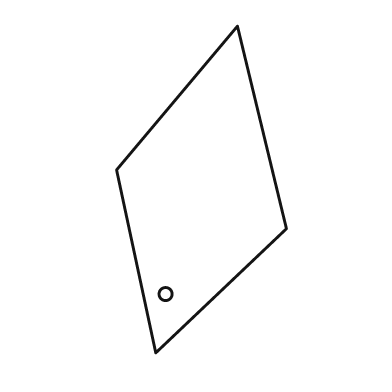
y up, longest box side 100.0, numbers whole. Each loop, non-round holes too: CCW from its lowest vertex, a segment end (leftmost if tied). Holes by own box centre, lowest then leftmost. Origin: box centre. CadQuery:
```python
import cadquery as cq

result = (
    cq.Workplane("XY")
    .moveTo(-14.0, -50.0)
    .lineTo(26.0, -12.0)
    .lineTo(11.0, 50.0)
    .lineTo(-26.0, 6.0)
    .close()
    .moveTo(-11.0, -32.0)
    .circle(2.0)
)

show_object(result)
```